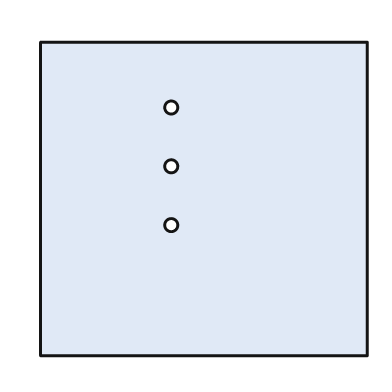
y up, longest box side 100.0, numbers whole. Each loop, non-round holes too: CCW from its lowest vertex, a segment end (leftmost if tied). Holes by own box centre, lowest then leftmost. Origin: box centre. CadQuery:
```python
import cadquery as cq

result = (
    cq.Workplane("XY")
    .moveTo(-50.0, -48.0)
    .lineTo(50.0, -48.0)
    .lineTo(50.0, 48.0)
    .lineTo(-50.0, 48.0)
    .close()
    .moveTo(-10.0, -8.0)
    .circle(2.0)
    .moveTo(-10.0, 10.0)
    .circle(2.0)
    .moveTo(-10.0, 28.0)
    .circle(2.0)
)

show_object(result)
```